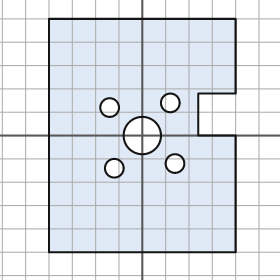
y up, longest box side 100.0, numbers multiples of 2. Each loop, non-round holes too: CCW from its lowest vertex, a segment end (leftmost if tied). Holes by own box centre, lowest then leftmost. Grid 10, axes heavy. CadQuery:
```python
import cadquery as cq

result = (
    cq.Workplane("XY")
    .moveTo(-40.0, -50.0)
    .lineTo(40.0, -50.0)
    .lineTo(40.0, 0.0)
    .lineTo(24.0, 0.0)
    .lineTo(24.0, 18.0)
    .lineTo(40.0, 18.0)
    .lineTo(40.0, 50.0)
    .lineTo(-40.0, 50.0)
    .close()
    .moveTo(-12.0, -14.0)
    .circle(4.0)
    .moveTo(14.0, -12.0)
    .circle(4.0)
    .moveTo(0.0, 0.0)
    .circle(8.0)
    .moveTo(-14.0, 12.0)
    .circle(4.0)
    .moveTo(12.0, 14.0)
    .circle(4.0)
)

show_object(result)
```